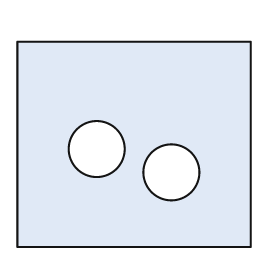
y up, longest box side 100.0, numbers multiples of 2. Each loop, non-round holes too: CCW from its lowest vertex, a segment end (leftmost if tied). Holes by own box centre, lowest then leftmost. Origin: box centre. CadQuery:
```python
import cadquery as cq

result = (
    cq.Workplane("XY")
    .moveTo(-50.0, -44.0)
    .lineTo(50.0, -44.0)
    .lineTo(50.0, 44.0)
    .lineTo(-50.0, 44.0)
    .close()
    .moveTo(16.0, -12.0)
    .circle(12.0)
    .moveTo(-16.0, -2.0)
    .circle(12.0)
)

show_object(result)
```